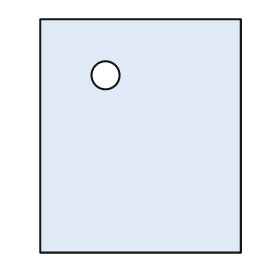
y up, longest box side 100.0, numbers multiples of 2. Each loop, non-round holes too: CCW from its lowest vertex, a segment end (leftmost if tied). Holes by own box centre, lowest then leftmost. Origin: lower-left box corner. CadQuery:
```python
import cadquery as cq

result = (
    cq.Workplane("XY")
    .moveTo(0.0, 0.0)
    .lineTo(86.0, 0.0)
    .lineTo(86.0, 100.0)
    .lineTo(0.0, 100.0)
    .close()
    .moveTo(28.0, 76.0)
    .circle(6.0)
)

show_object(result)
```